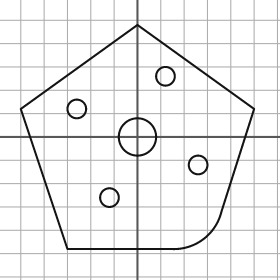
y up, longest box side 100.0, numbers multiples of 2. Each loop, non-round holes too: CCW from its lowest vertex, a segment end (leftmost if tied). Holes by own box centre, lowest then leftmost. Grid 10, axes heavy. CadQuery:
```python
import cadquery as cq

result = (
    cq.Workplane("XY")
    .moveTo(-30.0, -48.0)
    .lineTo(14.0, -48.0)
    .threePointArc((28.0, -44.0), (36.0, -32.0))
    .lineTo(50.0, 12.0)
    .lineTo(0.0, 48.0)
    .lineTo(-50.0, 12.0)
    .close()
    .moveTo(-12.0, -26.0)
    .circle(4.0)
    .moveTo(26.0, -12.0)
    .circle(4.0)
    .moveTo(0.0, 0.0)
    .circle(8.0)
    .moveTo(-26.0, 12.0)
    .circle(4.0)
    .moveTo(12.0, 26.0)
    .circle(4.0)
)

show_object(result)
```